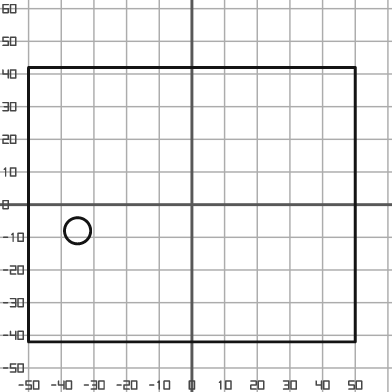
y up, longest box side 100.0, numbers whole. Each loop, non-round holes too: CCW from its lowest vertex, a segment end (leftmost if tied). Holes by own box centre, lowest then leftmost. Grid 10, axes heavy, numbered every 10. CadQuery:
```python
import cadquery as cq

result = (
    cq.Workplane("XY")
    .moveTo(-50.0, -42.0)
    .lineTo(50.0, -42.0)
    .lineTo(50.0, 42.0)
    .lineTo(-50.0, 42.0)
    .close()
    .moveTo(-35.0, -8.0)
    .circle(4.0)
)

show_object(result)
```